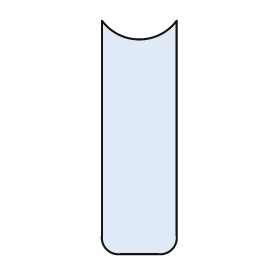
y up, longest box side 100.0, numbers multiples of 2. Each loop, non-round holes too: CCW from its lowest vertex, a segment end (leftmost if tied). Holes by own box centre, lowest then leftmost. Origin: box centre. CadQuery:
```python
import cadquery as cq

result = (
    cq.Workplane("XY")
    .moveTo(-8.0, -50.0)
    .lineTo(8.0, -50.0)
    .threePointArc((14.0, -48.0), (16.0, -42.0))
    .lineTo(16.0, 50.0)
    .threePointArc((0.0, 42.0), (-16.0, 50.0))
    .lineTo(-16.0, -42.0)
    .threePointArc((-14.0, -48.0), (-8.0, -50.0))
    .close()
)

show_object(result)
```